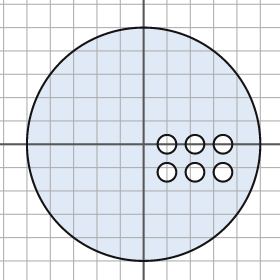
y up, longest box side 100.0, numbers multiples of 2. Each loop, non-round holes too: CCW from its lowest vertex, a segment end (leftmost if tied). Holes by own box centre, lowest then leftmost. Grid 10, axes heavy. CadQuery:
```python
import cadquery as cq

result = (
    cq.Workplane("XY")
    .moveTo(0.0, 0.0)
    .circle(50.0)
    .moveTo(10.0, -12.0)
    .circle(4.0)
    .moveTo(22.0, -12.0)
    .circle(4.0)
    .moveTo(34.0, -12.0)
    .circle(4.0)
    .moveTo(10.0, 0.0)
    .circle(4.0)
    .moveTo(22.0, 0.0)
    .circle(4.0)
    .moveTo(34.0, 0.0)
    .circle(4.0)
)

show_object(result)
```